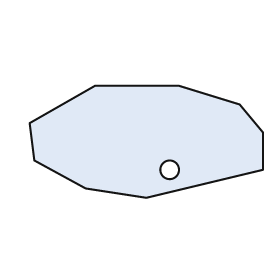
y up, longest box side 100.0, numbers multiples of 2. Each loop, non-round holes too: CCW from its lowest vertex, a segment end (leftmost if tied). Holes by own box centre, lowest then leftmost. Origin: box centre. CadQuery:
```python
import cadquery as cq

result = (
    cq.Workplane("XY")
    .moveTo(0.0, -24.0)
    .lineTo(50.0, -12.0)
    .lineTo(50.0, 4.0)
    .lineTo(40.0, 16.0)
    .lineTo(14.0, 24.0)
    .lineTo(-22.0, 24.0)
    .lineTo(-50.0, 8.0)
    .lineTo(-48.0, -8.0)
    .lineTo(-26.0, -20.0)
    .close()
    .moveTo(10.0, -12.0)
    .circle(4.0)
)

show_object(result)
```